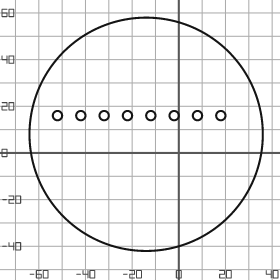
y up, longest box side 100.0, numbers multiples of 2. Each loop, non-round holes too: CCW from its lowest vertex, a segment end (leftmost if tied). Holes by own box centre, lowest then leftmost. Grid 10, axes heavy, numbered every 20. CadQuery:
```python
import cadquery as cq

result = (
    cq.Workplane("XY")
    .moveTo(-14.0, 8.0)
    .circle(50.0)
    .moveTo(-52.0, 16.0)
    .circle(2.0)
    .moveTo(-42.0, 16.0)
    .circle(2.0)
    .moveTo(-32.0, 16.0)
    .circle(2.0)
    .moveTo(-22.0, 16.0)
    .circle(2.0)
    .moveTo(-12.0, 16.0)
    .circle(2.0)
    .moveTo(-2.0, 16.0)
    .circle(2.0)
    .moveTo(8.0, 16.0)
    .circle(2.0)
    .moveTo(18.0, 16.0)
    .circle(2.0)
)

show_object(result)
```